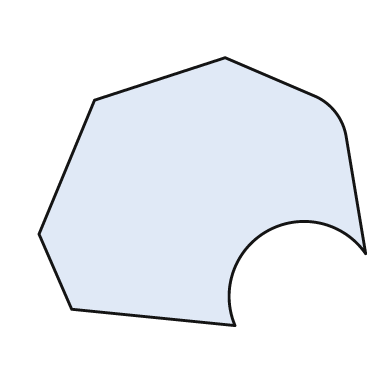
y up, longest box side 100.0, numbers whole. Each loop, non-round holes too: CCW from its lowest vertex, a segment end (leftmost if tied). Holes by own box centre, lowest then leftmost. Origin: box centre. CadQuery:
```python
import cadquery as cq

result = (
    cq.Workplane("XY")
    .moveTo(10.0, -41.0)
    .threePointArc((20.0, -12.0), (50.0, -19.0))
    .lineTo(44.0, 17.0)
    .threePointArc((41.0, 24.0), (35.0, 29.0))
    .lineTo(7.0, 41.0)
    .lineTo(-33.0, 28.0)
    .lineTo(-50.0, -13.0)
    .lineTo(-40.0, -36.0)
    .close()
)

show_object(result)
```